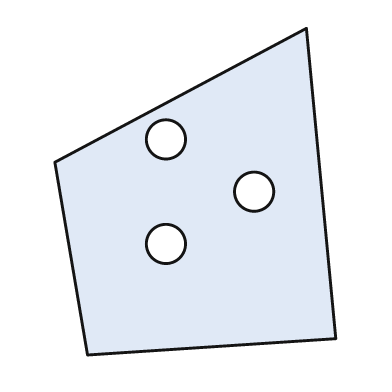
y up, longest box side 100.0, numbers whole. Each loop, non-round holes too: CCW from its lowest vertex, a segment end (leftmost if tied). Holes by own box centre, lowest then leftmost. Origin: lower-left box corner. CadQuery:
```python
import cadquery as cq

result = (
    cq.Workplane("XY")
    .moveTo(10.0, 0.0)
    .lineTo(86.0, 5.0)
    .lineTo(77.0, 100.0)
    .lineTo(0.0, 59.0)
    .close()
    .moveTo(34.0, 34.0)
    .circle(6.0)
    .moveTo(61.0, 50.0)
    .circle(6.0)
    .moveTo(34.0, 66.0)
    .circle(6.0)
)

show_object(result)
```